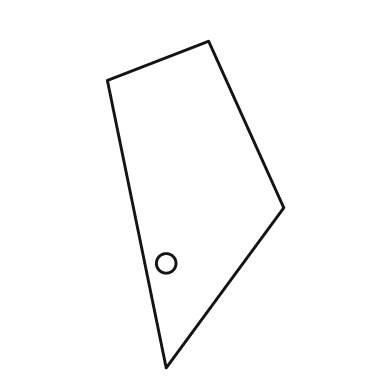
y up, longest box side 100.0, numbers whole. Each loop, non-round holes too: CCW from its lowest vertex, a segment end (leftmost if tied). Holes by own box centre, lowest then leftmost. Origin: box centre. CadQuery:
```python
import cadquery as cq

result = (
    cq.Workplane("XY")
    .moveTo(-9.0, -50.0)
    .lineTo(27.0, -1.0)
    .lineTo(4.0, 50.0)
    .lineTo(-27.0, 38.0)
    .close()
    .moveTo(-9.0, -18.0)
    .circle(3.0)
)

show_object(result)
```